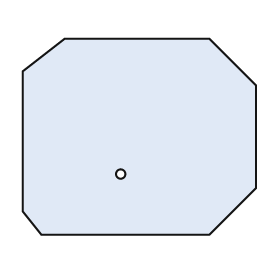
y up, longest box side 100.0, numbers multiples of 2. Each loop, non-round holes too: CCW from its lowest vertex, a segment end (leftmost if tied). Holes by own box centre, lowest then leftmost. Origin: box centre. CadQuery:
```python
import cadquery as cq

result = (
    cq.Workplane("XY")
    .moveTo(-42.0, -42.0)
    .lineTo(30.0, -42.0)
    .lineTo(50.0, -22.0)
    .lineTo(50.0, 22.0)
    .lineTo(30.0, 42.0)
    .lineTo(-32.0, 42.0)
    .lineTo(-50.0, 28.0)
    .lineTo(-50.0, -32.0)
    .close()
    .moveTo(-8.0, -16.0)
    .circle(2.0)
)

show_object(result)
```